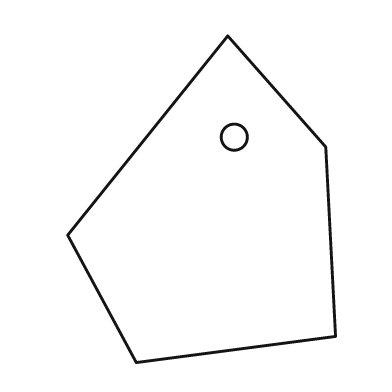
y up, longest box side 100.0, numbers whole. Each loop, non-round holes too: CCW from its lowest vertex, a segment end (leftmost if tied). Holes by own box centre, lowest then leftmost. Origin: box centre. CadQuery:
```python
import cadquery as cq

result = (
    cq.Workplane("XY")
    .moveTo(-20.0, -50.0)
    .lineTo(41.0, -42.0)
    .lineTo(38.0, 16.0)
    .lineTo(8.0, 50.0)
    .lineTo(-41.0, -11.0)
    .close()
    .moveTo(10.0, 19.0)
    .circle(4.0)
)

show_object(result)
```